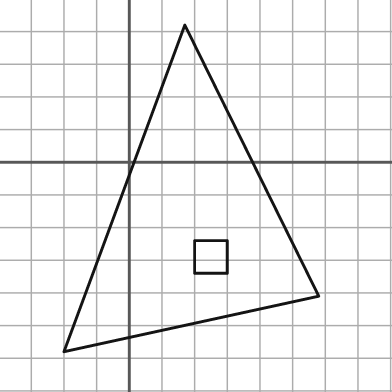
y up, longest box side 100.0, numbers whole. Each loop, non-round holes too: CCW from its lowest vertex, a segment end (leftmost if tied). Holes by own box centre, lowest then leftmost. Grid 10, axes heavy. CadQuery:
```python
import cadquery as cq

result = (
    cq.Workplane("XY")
    .moveTo(-20.0, -58.0)
    .lineTo(58.0, -41.0)
    .lineTo(17.0, 42.0)
    .close()
    .moveTo(20.0, -34.0)
    .lineTo(30.0, -34.0)
    .lineTo(30.0, -24.0)
    .lineTo(20.0, -24.0)
    .close()
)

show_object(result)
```